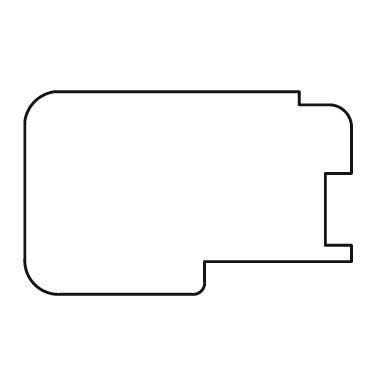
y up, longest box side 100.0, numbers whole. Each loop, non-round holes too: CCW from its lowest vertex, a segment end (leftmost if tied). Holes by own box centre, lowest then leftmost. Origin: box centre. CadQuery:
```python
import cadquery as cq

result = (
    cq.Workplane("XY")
    .moveTo(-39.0, -31.0)
    .lineTo(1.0, -31.0)
    .threePointArc((4.0, -30.0), (5.0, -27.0))
    .lineTo(5.0, -21.0)
    .lineTo(50.0, -21.0)
    .lineTo(50.0, -16.0)
    .lineTo(42.0, -16.0)
    .lineTo(42.0, 6.0)
    .lineTo(50.0, 6.0)
    .lineTo(50.0, 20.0)
    .threePointArc((48.0, 25.0), (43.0, 27.0))
    .lineTo(34.0, 27.0)
    .lineTo(34.0, 31.0)
    .lineTo(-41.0, 31.0)
    .threePointArc((-47.0, 28.0), (-50.0, 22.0))
    .lineTo(-50.0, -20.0)
    .threePointArc((-47.0, -28.0), (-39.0, -31.0))
    .close()
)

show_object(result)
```